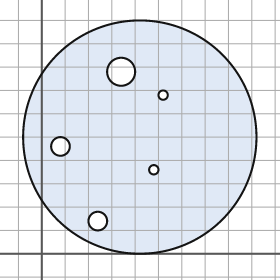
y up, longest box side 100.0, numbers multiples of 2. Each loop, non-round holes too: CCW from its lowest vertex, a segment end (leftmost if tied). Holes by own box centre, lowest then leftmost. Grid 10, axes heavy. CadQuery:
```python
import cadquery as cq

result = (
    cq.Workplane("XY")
    .moveTo(42.0, 50.0)
    .circle(50.0)
    .moveTo(24.0, 14.0)
    .circle(4.0)
    .moveTo(48.0, 36.0)
    .circle(2.0)
    .moveTo(8.0, 46.0)
    .circle(4.0)
    .moveTo(52.0, 68.0)
    .circle(2.0)
    .moveTo(34.0, 78.0)
    .circle(6.0)
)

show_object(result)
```